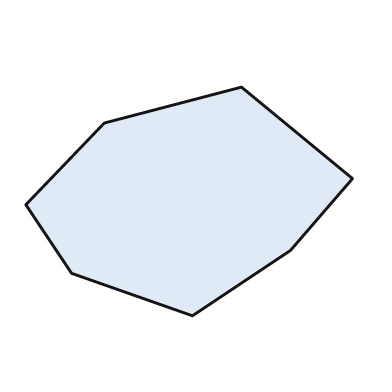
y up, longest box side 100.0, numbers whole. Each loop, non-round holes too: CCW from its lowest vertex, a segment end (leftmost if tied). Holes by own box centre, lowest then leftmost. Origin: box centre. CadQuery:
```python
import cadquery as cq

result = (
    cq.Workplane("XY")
    .moveTo(1.0, -35.0)
    .lineTo(31.0, -15.0)
    .lineTo(50.0, 7.0)
    .lineTo(16.0, 35.0)
    .lineTo(-26.0, 24.0)
    .lineTo(-50.0, -1.0)
    .lineTo(-36.0, -22.0)
    .close()
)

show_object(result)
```